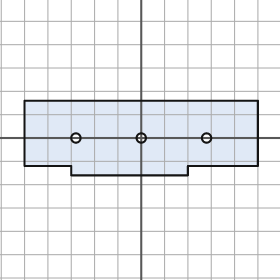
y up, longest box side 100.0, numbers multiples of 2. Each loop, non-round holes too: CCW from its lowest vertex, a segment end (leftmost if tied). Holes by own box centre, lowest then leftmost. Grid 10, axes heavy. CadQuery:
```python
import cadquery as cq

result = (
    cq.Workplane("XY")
    .moveTo(-30.0, -16.0)
    .lineTo(20.0, -16.0)
    .lineTo(20.0, -12.0)
    .lineTo(50.0, -12.0)
    .lineTo(50.0, 16.0)
    .lineTo(-50.0, 16.0)
    .lineTo(-50.0, -12.0)
    .lineTo(-30.0, -12.0)
    .close()
    .moveTo(-28.0, 0.0)
    .circle(2.0)
    .moveTo(0.0, 0.0)
    .circle(2.0)
    .moveTo(28.0, 0.0)
    .circle(2.0)
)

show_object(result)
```